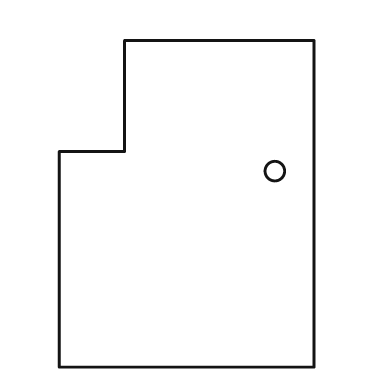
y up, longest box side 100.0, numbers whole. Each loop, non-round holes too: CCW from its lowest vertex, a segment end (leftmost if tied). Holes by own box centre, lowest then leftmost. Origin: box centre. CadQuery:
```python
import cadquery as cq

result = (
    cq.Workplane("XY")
    .moveTo(-39.0, -50.0)
    .lineTo(39.0, -50.0)
    .lineTo(39.0, 50.0)
    .lineTo(-19.0, 50.0)
    .lineTo(-19.0, 16.0)
    .lineTo(-39.0, 16.0)
    .close()
    .moveTo(27.0, 10.0)
    .circle(3.0)
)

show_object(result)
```